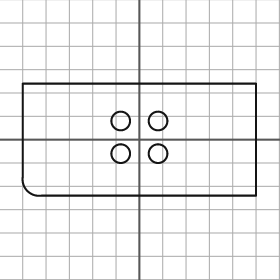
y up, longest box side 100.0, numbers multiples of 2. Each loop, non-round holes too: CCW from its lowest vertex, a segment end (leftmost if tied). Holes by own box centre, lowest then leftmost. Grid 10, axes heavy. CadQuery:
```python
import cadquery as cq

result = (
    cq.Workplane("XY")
    .moveTo(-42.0, -24.0)
    .lineTo(50.0, -24.0)
    .lineTo(50.0, 24.0)
    .lineTo(-50.0, 24.0)
    .lineTo(-50.0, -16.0)
    .threePointArc((-48.0, -22.0), (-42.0, -24.0))
    .close()
    .moveTo(-8.0, -6.0)
    .circle(4.0)
    .moveTo(8.0, -6.0)
    .circle(4.0)
    .moveTo(-8.0, 8.0)
    .circle(4.0)
    .moveTo(8.0, 8.0)
    .circle(4.0)
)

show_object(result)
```